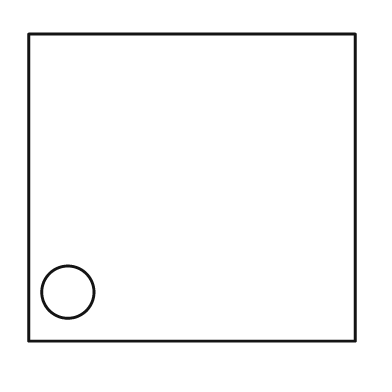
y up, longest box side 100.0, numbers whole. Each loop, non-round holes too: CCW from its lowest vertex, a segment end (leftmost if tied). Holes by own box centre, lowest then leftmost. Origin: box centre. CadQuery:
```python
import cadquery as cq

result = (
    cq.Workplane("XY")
    .moveTo(-50.0, -47.0)
    .lineTo(50.0, -47.0)
    .lineTo(50.0, 47.0)
    .lineTo(-50.0, 47.0)
    .close()
    .moveTo(-38.0, -32.0)
    .circle(8.0)
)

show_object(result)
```